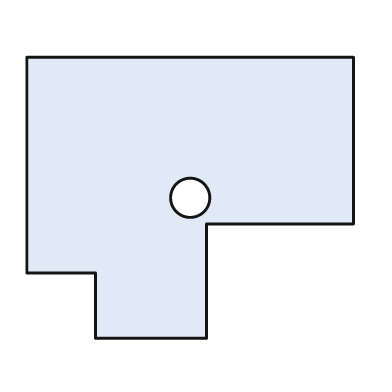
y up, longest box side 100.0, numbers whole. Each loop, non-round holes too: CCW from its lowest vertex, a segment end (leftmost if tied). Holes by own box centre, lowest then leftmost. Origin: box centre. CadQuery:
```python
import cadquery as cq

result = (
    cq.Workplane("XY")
    .moveTo(-29.0, -43.0)
    .lineTo(5.0, -43.0)
    .lineTo(5.0, -8.0)
    .lineTo(50.0, -8.0)
    .lineTo(50.0, 43.0)
    .lineTo(-50.0, 43.0)
    .lineTo(-50.0, -23.0)
    .lineTo(-29.0, -23.0)
    .close()
    .moveTo(0.0, 0.0)
    .circle(6.0)
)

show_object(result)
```